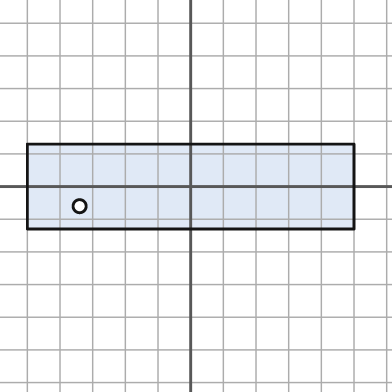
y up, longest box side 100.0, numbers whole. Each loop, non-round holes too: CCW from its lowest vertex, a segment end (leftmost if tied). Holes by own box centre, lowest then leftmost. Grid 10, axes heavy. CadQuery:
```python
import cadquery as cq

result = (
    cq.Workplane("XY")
    .moveTo(-50.0, -13.0)
    .lineTo(50.0, -13.0)
    .lineTo(50.0, 13.0)
    .lineTo(-50.0, 13.0)
    .close()
    .moveTo(-34.0, -6.0)
    .circle(2.0)
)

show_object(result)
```